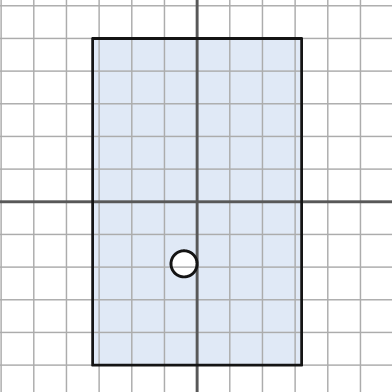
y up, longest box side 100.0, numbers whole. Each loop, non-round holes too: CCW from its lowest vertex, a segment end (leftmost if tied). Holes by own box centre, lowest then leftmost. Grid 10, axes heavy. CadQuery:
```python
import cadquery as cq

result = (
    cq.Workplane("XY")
    .moveTo(-32.0, -50.0)
    .lineTo(32.0, -50.0)
    .lineTo(32.0, 50.0)
    .lineTo(-32.0, 50.0)
    .close()
    .moveTo(-4.0, -19.0)
    .circle(4.0)
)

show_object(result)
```